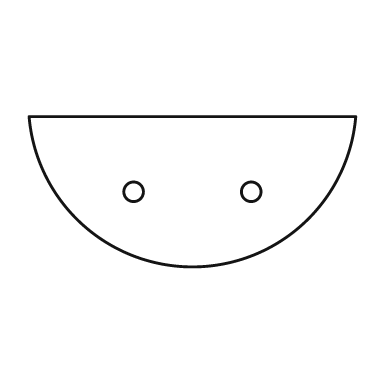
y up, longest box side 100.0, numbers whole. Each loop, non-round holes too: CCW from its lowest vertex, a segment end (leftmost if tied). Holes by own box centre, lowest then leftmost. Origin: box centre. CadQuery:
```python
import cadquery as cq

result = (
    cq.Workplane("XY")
    .moveTo(-50.0, 23.0)
    .threePointArc((0.0, -23.0), (50.0, 23.0))
    .close()
    .moveTo(-18.0, 0.0)
    .circle(3.0)
    .moveTo(18.0, 0.0)
    .circle(3.0)
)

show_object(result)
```